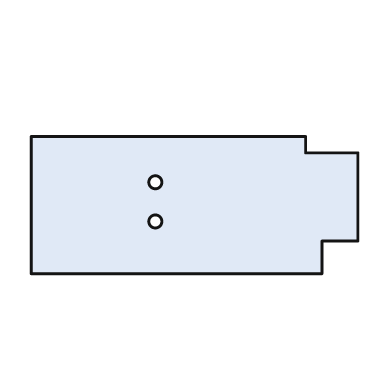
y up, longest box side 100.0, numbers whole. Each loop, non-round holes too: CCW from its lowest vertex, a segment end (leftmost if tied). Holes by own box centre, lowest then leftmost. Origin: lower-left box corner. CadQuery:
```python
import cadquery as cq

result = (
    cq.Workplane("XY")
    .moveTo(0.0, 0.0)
    .lineTo(89.0, 0.0)
    .lineTo(89.0, 10.0)
    .lineTo(100.0, 10.0)
    .lineTo(100.0, 37.0)
    .lineTo(84.0, 37.0)
    .lineTo(84.0, 42.0)
    .lineTo(0.0, 42.0)
    .close()
    .moveTo(38.0, 16.0)
    .circle(2.0)
    .moveTo(38.0, 28.0)
    .circle(2.0)
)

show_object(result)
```